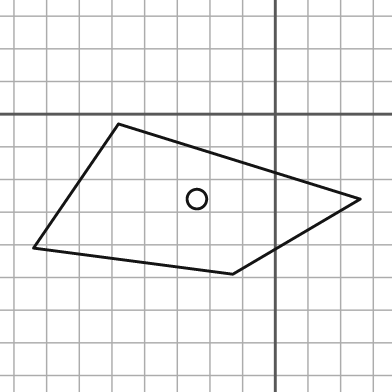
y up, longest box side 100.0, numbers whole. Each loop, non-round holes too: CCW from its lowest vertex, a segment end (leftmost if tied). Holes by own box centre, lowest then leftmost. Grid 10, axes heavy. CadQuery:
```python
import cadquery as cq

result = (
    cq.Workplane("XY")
    .moveTo(-13.0, -49.0)
    .lineTo(26.0, -26.0)
    .lineTo(-48.0, -3.0)
    .lineTo(-74.0, -41.0)
    .close()
    .moveTo(-24.0, -26.0)
    .circle(3.0)
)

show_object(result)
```